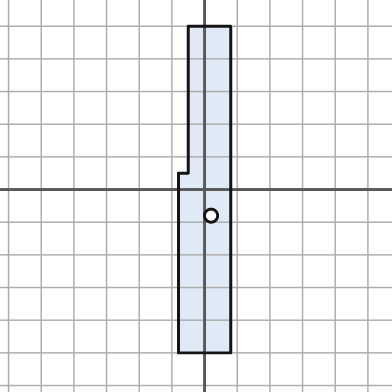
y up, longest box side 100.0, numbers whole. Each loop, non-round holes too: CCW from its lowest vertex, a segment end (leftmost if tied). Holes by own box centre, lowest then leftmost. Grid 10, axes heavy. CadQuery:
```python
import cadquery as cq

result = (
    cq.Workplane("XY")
    .moveTo(-8.0, -50.0)
    .lineTo(8.0, -50.0)
    .lineTo(8.0, 50.0)
    .lineTo(-5.0, 50.0)
    .lineTo(-5.0, 5.0)
    .lineTo(-8.0, 5.0)
    .close()
    .moveTo(2.0, -8.0)
    .circle(2.0)
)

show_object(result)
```